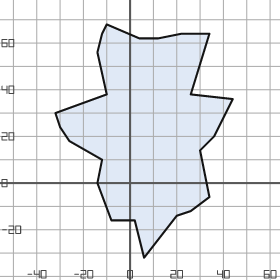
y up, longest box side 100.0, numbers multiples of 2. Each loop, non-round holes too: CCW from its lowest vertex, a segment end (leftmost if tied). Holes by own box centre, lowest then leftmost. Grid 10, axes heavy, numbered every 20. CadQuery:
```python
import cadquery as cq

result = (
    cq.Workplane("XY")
    .moveTo(6.0, -32.0)
    .lineTo(20.0, -14.0)
    .lineTo(26.0, -12.0)
    .lineTo(34.0, -6.0)
    .lineTo(30.0, 14.0)
    .lineTo(36.0, 20.0)
    .lineTo(44.0, 36.0)
    .lineTo(26.0, 38.0)
    .lineTo(34.0, 64.0)
    .lineTo(22.0, 64.0)
    .lineTo(12.0, 62.0)
    .lineTo(4.0, 62.0)
    .lineTo(-10.0, 68.0)
    .lineTo(-12.0, 64.0)
    .lineTo(-14.0, 56.0)
    .lineTo(-10.0, 38.0)
    .lineTo(-32.0, 30.0)
    .lineTo(-30.0, 24.0)
    .lineTo(-26.0, 18.0)
    .lineTo(-12.0, 10.0)
    .lineTo(-14.0, 0.0)
    .lineTo(-8.0, -16.0)
    .lineTo(2.0, -16.0)
    .close()
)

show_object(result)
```